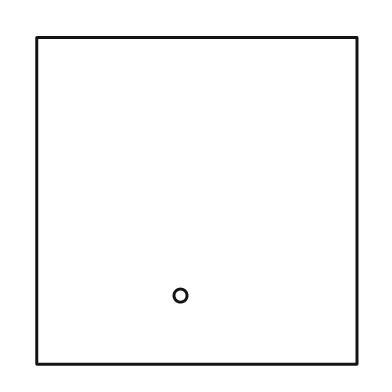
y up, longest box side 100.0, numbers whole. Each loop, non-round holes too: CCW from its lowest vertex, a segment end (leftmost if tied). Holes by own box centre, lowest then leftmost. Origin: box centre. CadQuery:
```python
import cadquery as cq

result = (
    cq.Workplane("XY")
    .moveTo(-49.0, -50.0)
    .lineTo(49.0, -50.0)
    .lineTo(49.0, 50.0)
    .lineTo(-49.0, 50.0)
    .close()
    .moveTo(-5.0, -29.0)
    .circle(2.0)
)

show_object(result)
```